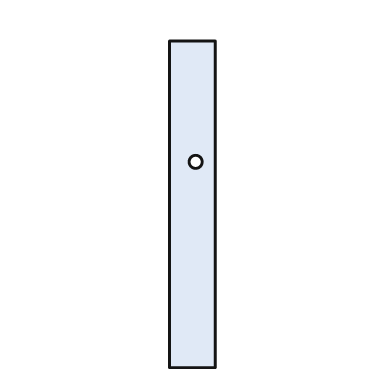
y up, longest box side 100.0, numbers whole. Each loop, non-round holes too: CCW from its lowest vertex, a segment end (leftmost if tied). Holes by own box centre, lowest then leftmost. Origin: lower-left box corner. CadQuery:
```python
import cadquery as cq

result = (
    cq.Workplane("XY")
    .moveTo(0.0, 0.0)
    .lineTo(14.0, 0.0)
    .lineTo(14.0, 100.0)
    .lineTo(0.0, 100.0)
    .close()
    .moveTo(8.0, 63.0)
    .circle(2.0)
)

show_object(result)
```